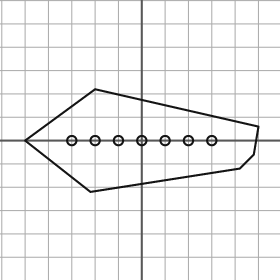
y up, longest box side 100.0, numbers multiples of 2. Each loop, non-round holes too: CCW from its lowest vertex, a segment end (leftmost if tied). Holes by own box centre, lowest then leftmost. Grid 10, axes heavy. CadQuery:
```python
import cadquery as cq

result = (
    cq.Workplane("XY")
    .moveTo(-22.0, -22.0)
    .lineTo(42.0, -12.0)
    .lineTo(48.0, -6.0)
    .lineTo(50.0, 6.0)
    .lineTo(-20.0, 22.0)
    .lineTo(-50.0, 0.0)
    .close()
    .moveTo(-30.0, 0.0)
    .circle(2.0)
    .moveTo(-20.0, 0.0)
    .circle(2.0)
    .moveTo(-10.0, 0.0)
    .circle(2.0)
    .moveTo(0.0, 0.0)
    .circle(2.0)
    .moveTo(10.0, 0.0)
    .circle(2.0)
    .moveTo(20.0, 0.0)
    .circle(2.0)
    .moveTo(30.0, 0.0)
    .circle(2.0)
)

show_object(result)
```